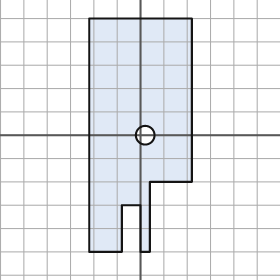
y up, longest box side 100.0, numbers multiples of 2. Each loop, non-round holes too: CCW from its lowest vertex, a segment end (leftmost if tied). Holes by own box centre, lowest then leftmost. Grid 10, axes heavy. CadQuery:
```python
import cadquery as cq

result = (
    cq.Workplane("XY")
    .moveTo(-22.0, -50.0)
    .lineTo(-8.0, -50.0)
    .lineTo(-8.0, -30.0)
    .lineTo(0.0, -30.0)
    .lineTo(0.0, -50.0)
    .lineTo(4.0, -50.0)
    .lineTo(4.0, -20.0)
    .lineTo(22.0, -20.0)
    .lineTo(22.0, 50.0)
    .lineTo(-22.0, 50.0)
    .close()
    .moveTo(2.0, 0.0)
    .circle(4.0)
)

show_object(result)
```